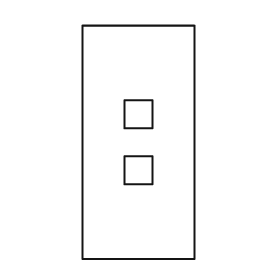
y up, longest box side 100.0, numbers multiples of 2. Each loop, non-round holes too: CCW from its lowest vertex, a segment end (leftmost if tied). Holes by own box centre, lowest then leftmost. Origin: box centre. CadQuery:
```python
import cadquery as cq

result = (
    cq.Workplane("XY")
    .moveTo(-24.0, -50.0)
    .lineTo(24.0, -50.0)
    .lineTo(24.0, 50.0)
    .lineTo(-24.0, 50.0)
    .close()
    .moveTo(-6.0, -18.0)
    .lineTo(6.0, -18.0)
    .lineTo(6.0, -6.0)
    .lineTo(-6.0, -6.0)
    .close()
    .moveTo(-6.0, 6.0)
    .lineTo(6.0, 6.0)
    .lineTo(6.0, 18.0)
    .lineTo(-6.0, 18.0)
    .close()
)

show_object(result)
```